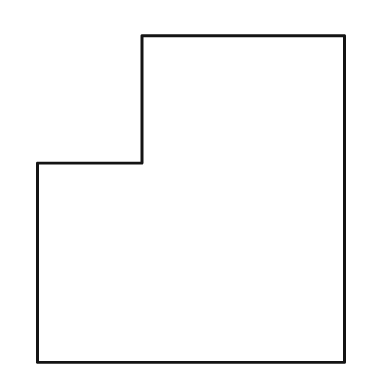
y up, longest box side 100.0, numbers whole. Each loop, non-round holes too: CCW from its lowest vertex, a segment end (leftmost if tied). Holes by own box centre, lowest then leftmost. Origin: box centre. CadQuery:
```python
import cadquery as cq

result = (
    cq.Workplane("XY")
    .moveTo(-47.0, -50.0)
    .lineTo(47.0, -50.0)
    .lineTo(47.0, 50.0)
    .lineTo(-15.0, 50.0)
    .lineTo(-15.0, 11.0)
    .lineTo(-47.0, 11.0)
    .close()
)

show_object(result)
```